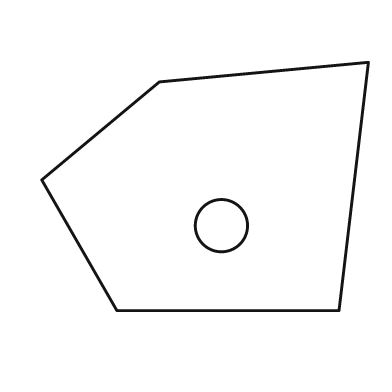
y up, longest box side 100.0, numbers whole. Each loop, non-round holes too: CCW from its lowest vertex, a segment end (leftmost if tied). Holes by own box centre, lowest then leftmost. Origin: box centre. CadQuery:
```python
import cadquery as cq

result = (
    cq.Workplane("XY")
    .moveTo(-27.0, -38.0)
    .lineTo(41.0, -38.0)
    .lineTo(50.0, 38.0)
    .lineTo(-14.0, 32.0)
    .lineTo(-50.0, 2.0)
    .close()
    .moveTo(5.0, -12.0)
    .circle(8.0)
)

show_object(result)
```